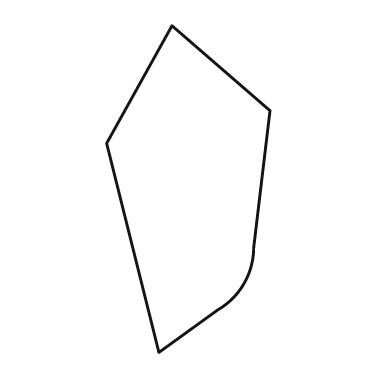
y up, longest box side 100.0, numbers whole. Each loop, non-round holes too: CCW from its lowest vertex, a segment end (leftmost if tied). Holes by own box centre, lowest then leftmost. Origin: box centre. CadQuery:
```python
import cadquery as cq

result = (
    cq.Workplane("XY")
    .moveTo(-9.0, -50.0)
    .lineTo(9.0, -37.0)
    .threePointArc((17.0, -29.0), (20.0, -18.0))
    .lineTo(25.0, 24.0)
    .lineTo(-5.0, 50.0)
    .lineTo(-25.0, 14.0)
    .close()
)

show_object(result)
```